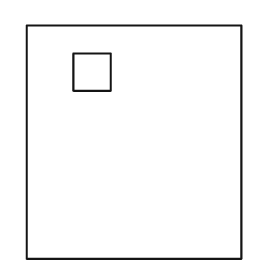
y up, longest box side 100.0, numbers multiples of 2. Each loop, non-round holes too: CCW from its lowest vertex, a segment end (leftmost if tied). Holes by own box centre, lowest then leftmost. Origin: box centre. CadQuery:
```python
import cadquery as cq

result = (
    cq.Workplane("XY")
    .moveTo(-46.0, -50.0)
    .lineTo(46.0, -50.0)
    .lineTo(46.0, 50.0)
    .lineTo(-46.0, 50.0)
    .close()
    .moveTo(-26.0, 22.0)
    .lineTo(-10.0, 22.0)
    .lineTo(-10.0, 38.0)
    .lineTo(-26.0, 38.0)
    .close()
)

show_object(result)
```